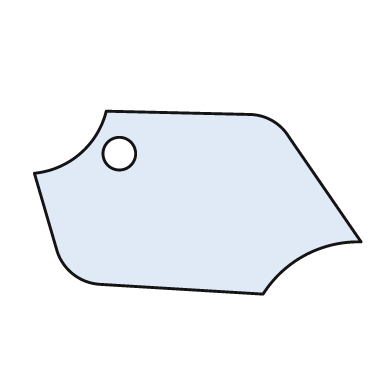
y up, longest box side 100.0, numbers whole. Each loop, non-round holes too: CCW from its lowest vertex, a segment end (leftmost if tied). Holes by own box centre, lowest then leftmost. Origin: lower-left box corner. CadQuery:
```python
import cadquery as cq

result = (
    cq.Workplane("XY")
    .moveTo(70.0, 0.0)
    .threePointArc((83.0, 12.0), (100.0, 16.0))
    .lineTo(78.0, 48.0)
    .threePointArc((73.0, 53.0), (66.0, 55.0))
    .lineTo(22.0, 56.0)
    .threePointArc((14.0, 43.0), (0.0, 37.0))
    .lineTo(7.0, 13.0)
    .threePointArc((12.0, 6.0), (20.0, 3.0))
    .close()
    .moveTo(26.0, 43.0)
    .circle(5.0)
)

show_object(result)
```